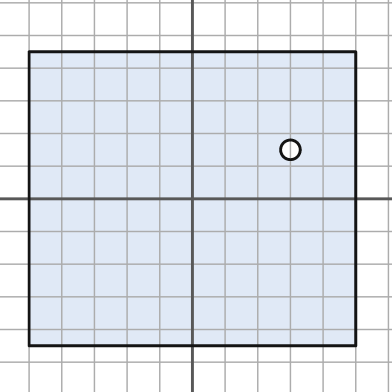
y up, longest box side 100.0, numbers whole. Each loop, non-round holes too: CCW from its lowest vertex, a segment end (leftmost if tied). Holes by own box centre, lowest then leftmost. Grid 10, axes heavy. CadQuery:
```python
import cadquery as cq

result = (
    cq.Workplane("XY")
    .moveTo(-50.0, -45.0)
    .lineTo(50.0, -45.0)
    .lineTo(50.0, 45.0)
    .lineTo(-50.0, 45.0)
    .close()
    .moveTo(30.0, 15.0)
    .circle(3.0)
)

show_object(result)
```